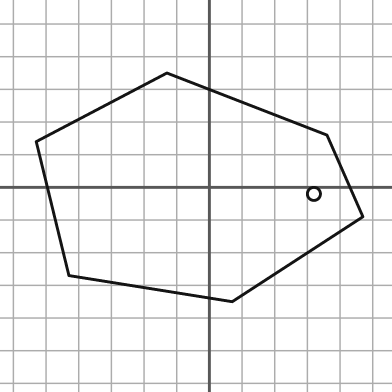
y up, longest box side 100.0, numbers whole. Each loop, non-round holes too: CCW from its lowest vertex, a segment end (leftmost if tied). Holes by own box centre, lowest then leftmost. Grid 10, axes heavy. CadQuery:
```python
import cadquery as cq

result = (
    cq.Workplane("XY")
    .moveTo(7.0, -35.0)
    .lineTo(47.0, -9.0)
    .lineTo(36.0, 16.0)
    .lineTo(-13.0, 35.0)
    .lineTo(-53.0, 14.0)
    .lineTo(-43.0, -27.0)
    .close()
    .moveTo(32.0, -2.0)
    .circle(2.0)
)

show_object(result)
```